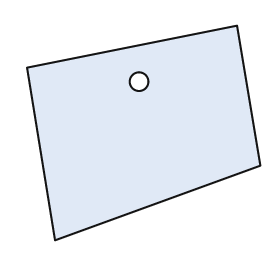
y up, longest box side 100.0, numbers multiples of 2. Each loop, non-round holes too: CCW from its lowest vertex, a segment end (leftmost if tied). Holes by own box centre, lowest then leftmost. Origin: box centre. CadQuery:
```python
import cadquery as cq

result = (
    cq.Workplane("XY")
    .moveTo(-38.0, -46.0)
    .lineTo(50.0, -14.0)
    .lineTo(40.0, 46.0)
    .lineTo(-50.0, 28.0)
    .close()
    .moveTo(-2.0, 22.0)
    .circle(4.0)
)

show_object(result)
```